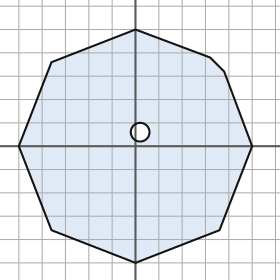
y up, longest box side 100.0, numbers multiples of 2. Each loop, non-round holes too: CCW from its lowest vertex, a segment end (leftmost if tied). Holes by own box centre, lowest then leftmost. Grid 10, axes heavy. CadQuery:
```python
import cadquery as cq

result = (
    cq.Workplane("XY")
    .moveTo(0.0, -50.0)
    .lineTo(36.0, -36.0)
    .lineTo(50.0, 0.0)
    .lineTo(38.0, 32.0)
    .lineTo(32.0, 38.0)
    .lineTo(0.0, 50.0)
    .lineTo(-36.0, 36.0)
    .lineTo(-50.0, 0.0)
    .lineTo(-36.0, -36.0)
    .close()
    .moveTo(2.0, 6.0)
    .circle(4.0)
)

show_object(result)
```